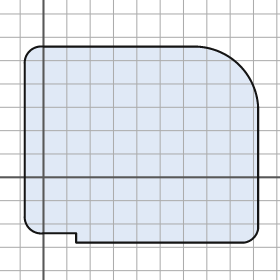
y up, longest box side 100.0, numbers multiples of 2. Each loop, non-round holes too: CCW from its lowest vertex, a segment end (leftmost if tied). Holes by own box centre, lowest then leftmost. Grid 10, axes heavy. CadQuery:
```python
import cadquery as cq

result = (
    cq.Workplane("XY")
    .moveTo(14.0, -28.0)
    .lineTo(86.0, -28.0)
    .threePointArc((90.0, -26.0), (92.0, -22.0))
    .lineTo(92.0, 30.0)
    .threePointArc((84.0, 48.0), (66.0, 56.0))
    .lineTo(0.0, 56.0)
    .threePointArc((-6.0, 54.0), (-8.0, 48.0))
    .lineTo(-8.0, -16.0)
    .threePointArc((-6.0, -22.0), (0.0, -24.0))
    .lineTo(14.0, -24.0)
    .close()
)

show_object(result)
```